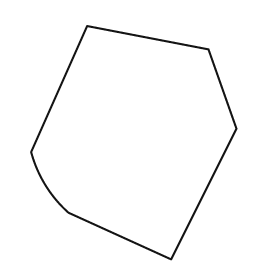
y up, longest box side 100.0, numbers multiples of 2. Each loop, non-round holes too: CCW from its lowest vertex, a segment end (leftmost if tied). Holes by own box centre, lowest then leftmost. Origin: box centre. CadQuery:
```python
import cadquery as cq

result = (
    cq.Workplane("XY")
    .moveTo(16.0, -50.0)
    .lineTo(44.0, 6.0)
    .lineTo(32.0, 40.0)
    .lineTo(-20.0, 50.0)
    .lineTo(-44.0, -4.0)
    .threePointArc((-38.0, -18.0), (-28.0, -30.0))
    .close()
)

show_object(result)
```